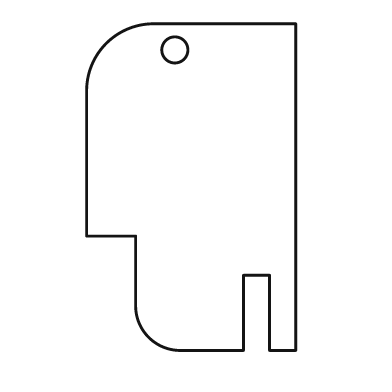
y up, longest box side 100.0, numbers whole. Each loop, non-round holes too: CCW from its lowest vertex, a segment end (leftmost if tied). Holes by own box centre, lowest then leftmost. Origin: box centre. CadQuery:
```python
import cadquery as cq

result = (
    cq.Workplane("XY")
    .moveTo(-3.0, -50.0)
    .lineTo(16.0, -50.0)
    .lineTo(16.0, -27.0)
    .lineTo(24.0, -27.0)
    .lineTo(24.0, -50.0)
    .lineTo(32.0, -50.0)
    .lineTo(32.0, 50.0)
    .lineTo(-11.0, 50.0)
    .threePointArc((-26.0, 44.0), (-32.0, 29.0))
    .lineTo(-32.0, -15.0)
    .lineTo(-17.0, -15.0)
    .lineTo(-17.0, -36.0)
    .threePointArc((-13.0, -46.0), (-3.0, -50.0))
    .close()
    .moveTo(-5.0, 42.0)
    .circle(4.0)
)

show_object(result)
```